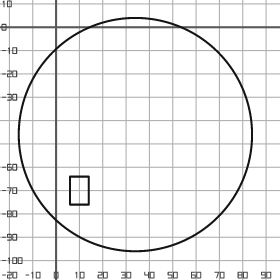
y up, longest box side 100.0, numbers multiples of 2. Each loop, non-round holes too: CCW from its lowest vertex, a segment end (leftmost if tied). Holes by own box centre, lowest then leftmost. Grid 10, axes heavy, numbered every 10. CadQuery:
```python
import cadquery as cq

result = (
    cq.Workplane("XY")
    .moveTo(34.0, -46.0)
    .circle(50.0)
    .moveTo(6.0, -76.0)
    .lineTo(14.0, -76.0)
    .lineTo(14.0, -64.0)
    .lineTo(6.0, -64.0)
    .close()
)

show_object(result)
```